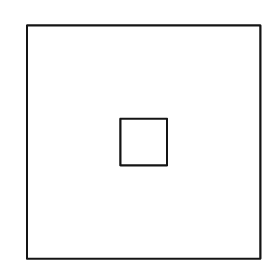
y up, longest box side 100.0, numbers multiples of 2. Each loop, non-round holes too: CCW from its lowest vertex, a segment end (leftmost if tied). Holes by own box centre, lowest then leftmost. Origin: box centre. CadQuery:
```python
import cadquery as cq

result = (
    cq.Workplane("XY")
    .moveTo(-50.0, -50.0)
    .lineTo(50.0, -50.0)
    .lineTo(50.0, 50.0)
    .lineTo(-50.0, 50.0)
    .close()
    .moveTo(-10.0, -10.0)
    .lineTo(10.0, -10.0)
    .lineTo(10.0, 10.0)
    .lineTo(-10.0, 10.0)
    .close()
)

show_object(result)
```